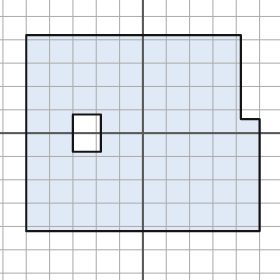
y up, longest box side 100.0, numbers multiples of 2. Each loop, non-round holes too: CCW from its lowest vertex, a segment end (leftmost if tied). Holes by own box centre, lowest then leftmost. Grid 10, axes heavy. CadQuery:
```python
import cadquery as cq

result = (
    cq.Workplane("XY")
    .moveTo(-50.0, -42.0)
    .lineTo(50.0, -42.0)
    .lineTo(50.0, 6.0)
    .lineTo(42.0, 6.0)
    .lineTo(42.0, 42.0)
    .lineTo(-50.0, 42.0)
    .close()
    .moveTo(-30.0, -8.0)
    .lineTo(-18.0, -8.0)
    .lineTo(-18.0, 8.0)
    .lineTo(-30.0, 8.0)
    .close()
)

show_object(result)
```